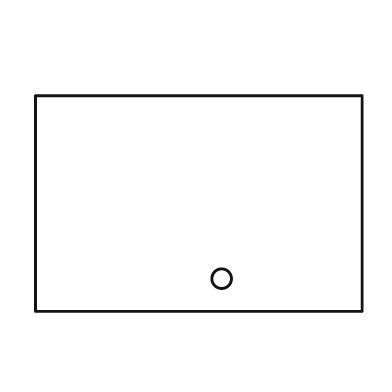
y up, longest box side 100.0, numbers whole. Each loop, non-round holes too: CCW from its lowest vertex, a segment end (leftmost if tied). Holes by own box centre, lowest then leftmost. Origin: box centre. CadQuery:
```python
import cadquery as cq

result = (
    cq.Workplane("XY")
    .moveTo(-50.0, -33.0)
    .lineTo(50.0, -33.0)
    .lineTo(50.0, 33.0)
    .lineTo(-50.0, 33.0)
    .close()
    .moveTo(7.0, -23.0)
    .circle(3.0)
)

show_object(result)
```